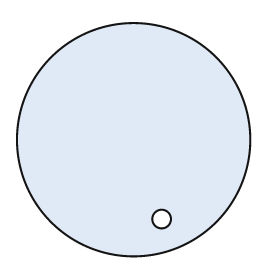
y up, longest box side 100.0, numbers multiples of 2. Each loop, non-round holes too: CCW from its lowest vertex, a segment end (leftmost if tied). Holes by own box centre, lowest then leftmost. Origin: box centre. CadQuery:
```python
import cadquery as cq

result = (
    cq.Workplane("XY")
    .moveTo(0.0, 0.0)
    .circle(50.0)
    .moveTo(12.0, -34.0)
    .circle(4.0)
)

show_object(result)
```